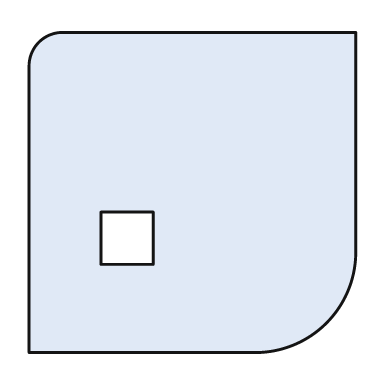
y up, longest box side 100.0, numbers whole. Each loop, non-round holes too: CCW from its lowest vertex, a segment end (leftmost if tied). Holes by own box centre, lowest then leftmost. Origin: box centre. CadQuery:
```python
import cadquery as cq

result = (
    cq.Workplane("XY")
    .moveTo(-50.0, -49.0)
    .lineTo(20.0, -49.0)
    .threePointArc((41.0, -40.0), (50.0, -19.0))
    .lineTo(50.0, 49.0)
    .lineTo(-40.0, 49.0)
    .threePointArc((-47.0, 46.0), (-50.0, 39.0))
    .close()
    .moveTo(-28.0, -22.0)
    .lineTo(-12.0, -22.0)
    .lineTo(-12.0, -6.0)
    .lineTo(-28.0, -6.0)
    .close()
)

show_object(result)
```